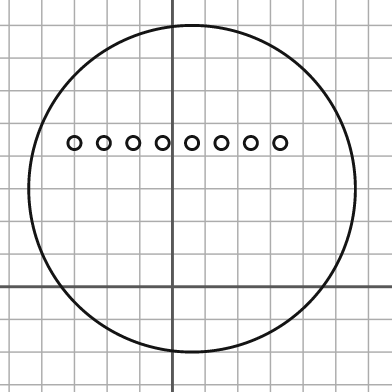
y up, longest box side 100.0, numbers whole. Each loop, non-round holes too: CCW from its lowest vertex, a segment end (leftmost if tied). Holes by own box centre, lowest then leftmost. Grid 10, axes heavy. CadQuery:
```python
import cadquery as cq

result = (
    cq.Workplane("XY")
    .moveTo(6.0, 30.0)
    .circle(50.0)
    .moveTo(-30.0, 44.0)
    .circle(2.0)
    .moveTo(-21.0, 44.0)
    .circle(2.0)
    .moveTo(-12.0, 44.0)
    .circle(2.0)
    .moveTo(-3.0, 44.0)
    .circle(2.0)
    .moveTo(6.0, 44.0)
    .circle(2.0)
    .moveTo(15.0, 44.0)
    .circle(2.0)
    .moveTo(24.0, 44.0)
    .circle(2.0)
    .moveTo(33.0, 44.0)
    .circle(2.0)
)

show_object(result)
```